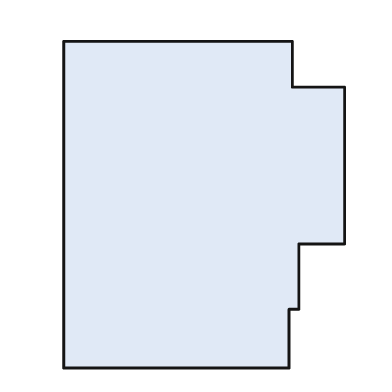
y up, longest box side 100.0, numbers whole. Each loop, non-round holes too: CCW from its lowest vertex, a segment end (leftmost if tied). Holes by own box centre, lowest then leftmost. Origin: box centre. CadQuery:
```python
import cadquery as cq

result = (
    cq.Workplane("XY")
    .moveTo(-43.0, -50.0)
    .lineTo(26.0, -50.0)
    .lineTo(26.0, -32.0)
    .lineTo(29.0, -32.0)
    .lineTo(29.0, -12.0)
    .lineTo(43.0, -12.0)
    .lineTo(43.0, 36.0)
    .lineTo(27.0, 36.0)
    .lineTo(27.0, 50.0)
    .lineTo(-43.0, 50.0)
    .close()
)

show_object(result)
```